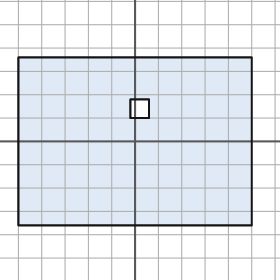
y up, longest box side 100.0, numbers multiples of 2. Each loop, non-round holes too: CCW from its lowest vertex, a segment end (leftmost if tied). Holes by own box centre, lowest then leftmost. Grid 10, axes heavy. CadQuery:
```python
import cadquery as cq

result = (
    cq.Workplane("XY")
    .moveTo(-50.0, -36.0)
    .lineTo(50.0, -36.0)
    .lineTo(50.0, 36.0)
    .lineTo(-50.0, 36.0)
    .close()
    .moveTo(-2.0, 10.0)
    .lineTo(6.0, 10.0)
    .lineTo(6.0, 18.0)
    .lineTo(-2.0, 18.0)
    .close()
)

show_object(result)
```